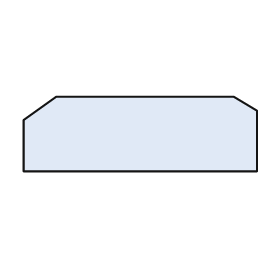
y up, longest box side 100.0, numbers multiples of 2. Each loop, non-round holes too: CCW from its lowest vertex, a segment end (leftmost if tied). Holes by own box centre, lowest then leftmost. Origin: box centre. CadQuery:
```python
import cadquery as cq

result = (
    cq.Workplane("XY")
    .moveTo(-50.0, -16.0)
    .lineTo(50.0, -16.0)
    .lineTo(50.0, 10.0)
    .lineTo(40.0, 16.0)
    .lineTo(-36.0, 16.0)
    .lineTo(-50.0, 6.0)
    .close()
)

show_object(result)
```